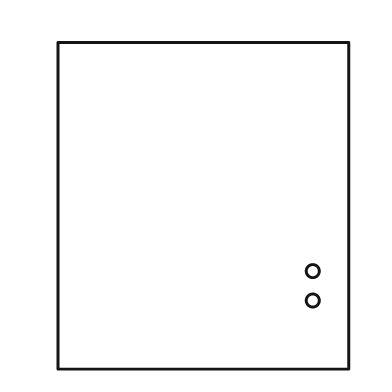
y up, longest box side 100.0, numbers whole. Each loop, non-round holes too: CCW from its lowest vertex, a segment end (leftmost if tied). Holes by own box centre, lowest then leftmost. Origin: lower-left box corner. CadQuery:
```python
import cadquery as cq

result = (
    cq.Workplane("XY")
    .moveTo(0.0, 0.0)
    .lineTo(89.0, 0.0)
    .lineTo(89.0, 100.0)
    .lineTo(0.0, 100.0)
    .close()
    .moveTo(78.0, 21.0)
    .circle(2.0)
    .moveTo(78.0, 30.0)
    .circle(2.0)
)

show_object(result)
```